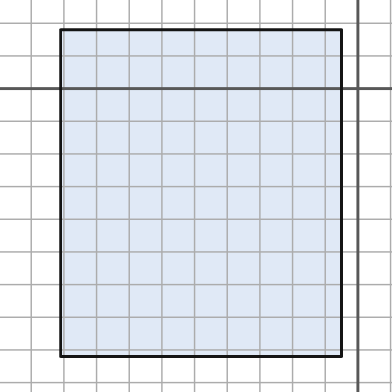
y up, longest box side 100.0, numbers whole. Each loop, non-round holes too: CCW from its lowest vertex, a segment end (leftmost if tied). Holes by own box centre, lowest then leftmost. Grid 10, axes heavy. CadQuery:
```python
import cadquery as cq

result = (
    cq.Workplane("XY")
    .moveTo(-91.0, -82.0)
    .lineTo(-5.0, -82.0)
    .lineTo(-5.0, 18.0)
    .lineTo(-91.0, 18.0)
    .close()
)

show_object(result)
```